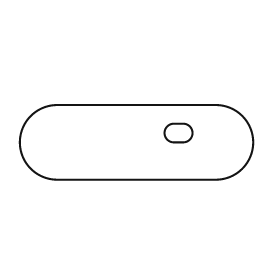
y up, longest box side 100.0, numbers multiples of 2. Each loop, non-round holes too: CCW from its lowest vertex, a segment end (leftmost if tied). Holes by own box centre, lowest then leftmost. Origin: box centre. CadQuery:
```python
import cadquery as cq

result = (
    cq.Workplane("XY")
    .moveTo(-34.0, -16.0)
    .lineTo(34.0, -16.0)
    .threePointArc((50.0, 0.0), (34.0, 16.0))
    .lineTo(-34.0, 16.0)
    .threePointArc((-50.0, 0.0), (-34.0, -16.0))
    .close()
    .moveTo(16.0, 0.0)
    .lineTo(20.0, 0.0)
    .threePointArc((24.0, 4.0), (20.0, 8.0))
    .lineTo(16.0, 8.0)
    .threePointArc((12.0, 4.0), (16.0, 0.0))
    .close()
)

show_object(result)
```